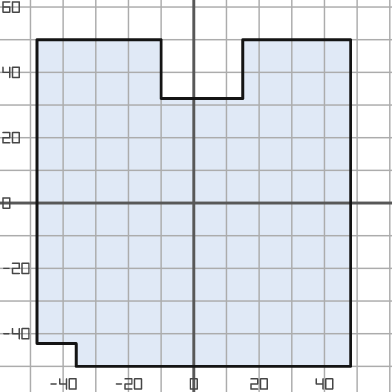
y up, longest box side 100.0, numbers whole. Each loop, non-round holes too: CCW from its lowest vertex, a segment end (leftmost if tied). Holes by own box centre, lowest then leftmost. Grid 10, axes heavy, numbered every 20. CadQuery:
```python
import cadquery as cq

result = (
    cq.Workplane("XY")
    .moveTo(-36.0, -50.0)
    .lineTo(48.0, -50.0)
    .lineTo(48.0, 50.0)
    .lineTo(15.0, 50.0)
    .lineTo(15.0, 32.0)
    .lineTo(-10.0, 32.0)
    .lineTo(-10.0, 50.0)
    .lineTo(-48.0, 50.0)
    .lineTo(-48.0, -43.0)
    .lineTo(-36.0, -43.0)
    .close()
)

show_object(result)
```